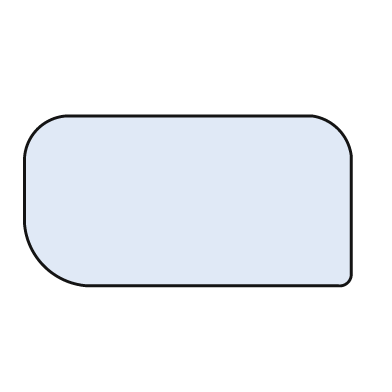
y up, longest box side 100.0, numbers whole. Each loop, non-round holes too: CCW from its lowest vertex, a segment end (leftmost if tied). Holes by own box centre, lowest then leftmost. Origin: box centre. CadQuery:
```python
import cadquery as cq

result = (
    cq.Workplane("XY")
    .moveTo(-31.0, -26.0)
    .lineTo(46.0, -26.0)
    .threePointArc((49.0, -25.0), (50.0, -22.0))
    .lineTo(50.0, 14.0)
    .threePointArc((46.0, 22.0), (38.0, 26.0))
    .lineTo(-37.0, 26.0)
    .threePointArc((-46.0, 22.0), (-50.0, 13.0))
    .lineTo(-50.0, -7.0)
    .threePointArc((-44.0, -20.0), (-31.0, -26.0))
    .close()
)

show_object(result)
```